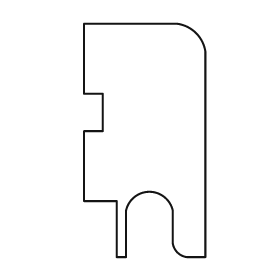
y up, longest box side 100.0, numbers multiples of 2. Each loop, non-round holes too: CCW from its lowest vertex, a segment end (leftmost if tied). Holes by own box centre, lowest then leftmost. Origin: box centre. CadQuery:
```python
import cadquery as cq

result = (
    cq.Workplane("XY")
    .moveTo(-12.0, -50.0)
    .lineTo(-8.0, -50.0)
    .lineTo(-8.0, -30.0)
    .threePointArc((2.0, -22.0), (12.0, -30.0))
    .lineTo(12.0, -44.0)
    .threePointArc((14.0, -48.0), (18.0, -50.0))
    .lineTo(26.0, -50.0)
    .lineTo(26.0, 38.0)
    .threePointArc((22.0, 46.0), (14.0, 50.0))
    .lineTo(-26.0, 50.0)
    .lineTo(-26.0, 20.0)
    .lineTo(-18.0, 20.0)
    .lineTo(-18.0, 4.0)
    .lineTo(-26.0, 4.0)
    .lineTo(-26.0, -26.0)
    .lineTo(-12.0, -26.0)
    .close()
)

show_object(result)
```